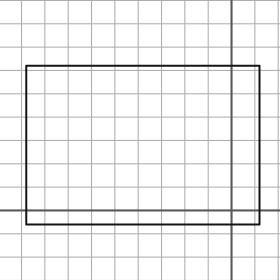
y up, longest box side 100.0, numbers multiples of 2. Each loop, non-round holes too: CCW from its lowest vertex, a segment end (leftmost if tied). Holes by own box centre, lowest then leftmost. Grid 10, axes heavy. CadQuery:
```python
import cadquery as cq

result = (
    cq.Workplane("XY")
    .moveTo(-88.0, -6.0)
    .lineTo(12.0, -6.0)
    .lineTo(12.0, 62.0)
    .lineTo(-88.0, 62.0)
    .close()
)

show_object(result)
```